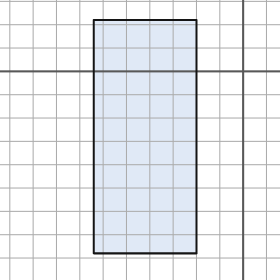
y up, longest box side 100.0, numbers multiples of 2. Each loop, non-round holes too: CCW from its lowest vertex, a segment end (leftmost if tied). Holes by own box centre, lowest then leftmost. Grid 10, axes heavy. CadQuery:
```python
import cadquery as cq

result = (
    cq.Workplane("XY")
    .moveTo(-64.0, -78.0)
    .lineTo(-20.0, -78.0)
    .lineTo(-20.0, 22.0)
    .lineTo(-64.0, 22.0)
    .close()
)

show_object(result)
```